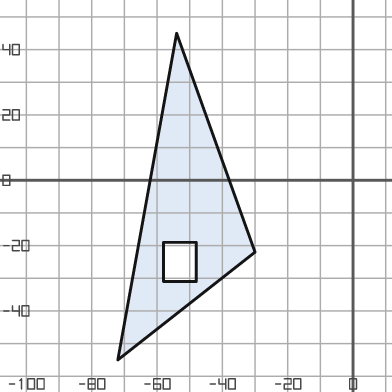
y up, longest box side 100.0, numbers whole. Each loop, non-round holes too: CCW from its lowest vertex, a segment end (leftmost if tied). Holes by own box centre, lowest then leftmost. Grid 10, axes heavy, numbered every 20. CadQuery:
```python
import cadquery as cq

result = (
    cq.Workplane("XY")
    .moveTo(-72.0, -55.0)
    .lineTo(-30.0, -22.0)
    .lineTo(-54.0, 45.0)
    .close()
    .moveTo(-58.0, -31.0)
    .lineTo(-48.0, -31.0)
    .lineTo(-48.0, -19.0)
    .lineTo(-58.0, -19.0)
    .close()
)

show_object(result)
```